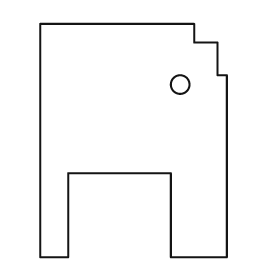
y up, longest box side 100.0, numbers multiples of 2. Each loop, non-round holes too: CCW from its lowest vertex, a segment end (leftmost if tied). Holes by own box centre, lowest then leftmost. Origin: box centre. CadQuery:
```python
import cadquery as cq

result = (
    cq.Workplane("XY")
    .moveTo(-40.0, -50.0)
    .lineTo(-28.0, -50.0)
    .lineTo(-28.0, -14.0)
    .lineTo(16.0, -14.0)
    .lineTo(16.0, -50.0)
    .lineTo(40.0, -50.0)
    .lineTo(40.0, 28.0)
    .lineTo(36.0, 28.0)
    .lineTo(36.0, 42.0)
    .lineTo(26.0, 42.0)
    .lineTo(26.0, 50.0)
    .lineTo(-40.0, 50.0)
    .close()
    .moveTo(20.0, 24.0)
    .circle(4.0)
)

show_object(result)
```